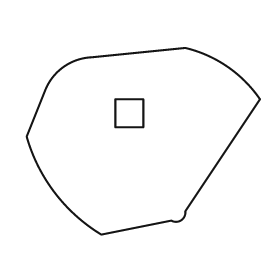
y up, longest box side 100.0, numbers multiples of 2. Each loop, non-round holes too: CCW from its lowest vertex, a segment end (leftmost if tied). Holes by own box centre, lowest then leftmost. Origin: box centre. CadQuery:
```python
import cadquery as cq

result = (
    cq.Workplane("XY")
    .moveTo(-18.0, -40.0)
    .lineTo(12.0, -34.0)
    .threePointArc((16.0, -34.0), (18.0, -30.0))
    .lineTo(50.0, 18.0)
    .threePointArc((36.0, 32.0), (18.0, 40.0))
    .lineTo(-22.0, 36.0)
    .threePointArc((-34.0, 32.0), (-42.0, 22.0))
    .lineTo(-50.0, 2.0)
    .threePointArc((-38.0, -22.0), (-18.0, -40.0))
    .close()
    .moveTo(-12.0, 6.0)
    .lineTo(0.0, 6.0)
    .lineTo(0.0, 18.0)
    .lineTo(-12.0, 18.0)
    .close()
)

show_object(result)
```